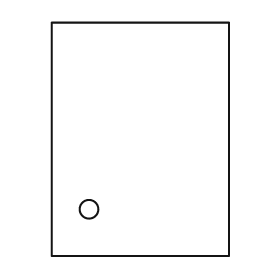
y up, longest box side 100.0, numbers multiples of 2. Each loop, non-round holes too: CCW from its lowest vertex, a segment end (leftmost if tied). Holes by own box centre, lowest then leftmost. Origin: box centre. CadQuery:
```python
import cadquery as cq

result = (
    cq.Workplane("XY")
    .moveTo(-38.0, -50.0)
    .lineTo(38.0, -50.0)
    .lineTo(38.0, 50.0)
    .lineTo(-38.0, 50.0)
    .close()
    .moveTo(-22.0, -30.0)
    .circle(4.0)
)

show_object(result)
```